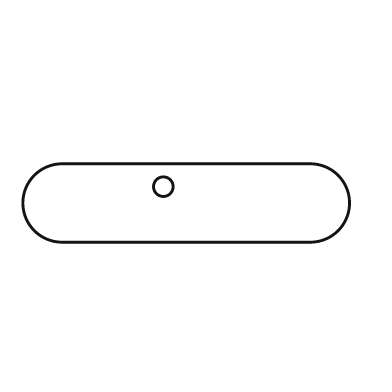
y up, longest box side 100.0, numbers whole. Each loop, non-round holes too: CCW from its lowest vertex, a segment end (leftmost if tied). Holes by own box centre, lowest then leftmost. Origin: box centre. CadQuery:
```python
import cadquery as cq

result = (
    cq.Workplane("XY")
    .moveTo(-38.0, -12.0)
    .lineTo(38.0, -12.0)
    .threePointArc((50.0, 0.0), (38.0, 12.0))
    .lineTo(-38.0, 12.0)
    .threePointArc((-50.0, 0.0), (-38.0, -12.0))
    .close()
    .moveTo(-7.0, 5.0)
    .circle(3.0)
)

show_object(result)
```